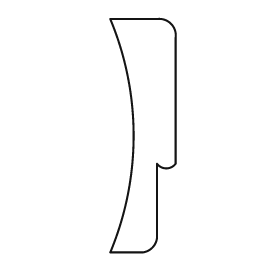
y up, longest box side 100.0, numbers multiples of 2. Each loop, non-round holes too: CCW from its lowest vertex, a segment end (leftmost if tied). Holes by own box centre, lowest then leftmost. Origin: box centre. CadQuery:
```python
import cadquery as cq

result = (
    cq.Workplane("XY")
    .moveTo(-14.0, -50.0)
    .lineTo(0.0, -50.0)
    .threePointArc((4.0, -48.0), (6.0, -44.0))
    .lineTo(6.0, -12.0)
    .threePointArc((10.0, -14.0), (14.0, -12.0))
    .lineTo(14.0, 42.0)
    .threePointArc((12.0, 48.0), (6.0, 50.0))
    .lineTo(-14.0, 50.0)
    .threePointArc((-4.0, 0.0), (-14.0, -50.0))
    .close()
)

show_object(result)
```